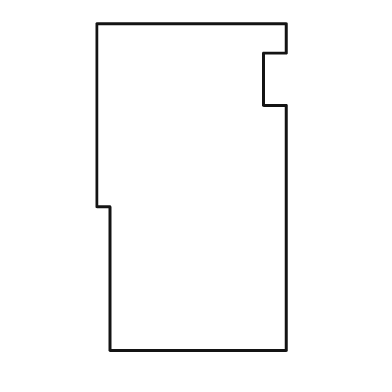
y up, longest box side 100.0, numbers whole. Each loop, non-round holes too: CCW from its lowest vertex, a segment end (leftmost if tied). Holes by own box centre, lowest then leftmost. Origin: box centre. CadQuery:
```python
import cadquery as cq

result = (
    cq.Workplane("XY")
    .moveTo(-25.0, -50.0)
    .lineTo(29.0, -50.0)
    .lineTo(29.0, 25.0)
    .lineTo(22.0, 25.0)
    .lineTo(22.0, 41.0)
    .lineTo(29.0, 41.0)
    .lineTo(29.0, 50.0)
    .lineTo(-29.0, 50.0)
    .lineTo(-29.0, -6.0)
    .lineTo(-25.0, -6.0)
    .close()
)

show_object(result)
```